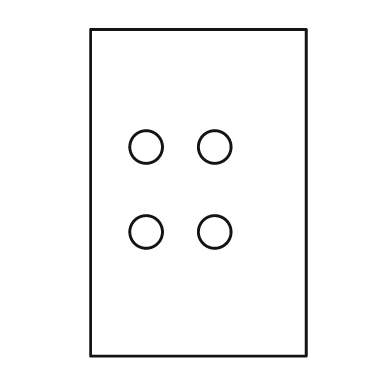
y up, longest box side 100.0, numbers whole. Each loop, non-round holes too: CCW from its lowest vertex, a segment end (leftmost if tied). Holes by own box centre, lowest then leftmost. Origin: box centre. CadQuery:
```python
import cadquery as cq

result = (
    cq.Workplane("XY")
    .moveTo(-33.0, -50.0)
    .lineTo(33.0, -50.0)
    .lineTo(33.0, 50.0)
    .lineTo(-33.0, 50.0)
    .close()
    .moveTo(-16.0, -12.0)
    .circle(5.0)
    .moveTo(5.0, -12.0)
    .circle(5.0)
    .moveTo(-16.0, 14.0)
    .circle(5.0)
    .moveTo(5.0, 14.0)
    .circle(5.0)
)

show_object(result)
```